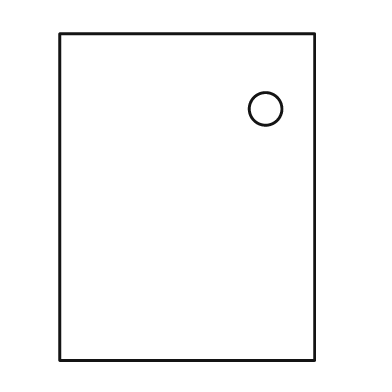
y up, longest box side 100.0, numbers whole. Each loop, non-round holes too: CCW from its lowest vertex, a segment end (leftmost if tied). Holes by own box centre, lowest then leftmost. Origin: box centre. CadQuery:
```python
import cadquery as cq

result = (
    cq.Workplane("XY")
    .moveTo(-39.0, -50.0)
    .lineTo(39.0, -50.0)
    .lineTo(39.0, 50.0)
    .lineTo(-39.0, 50.0)
    .close()
    .moveTo(24.0, 27.0)
    .circle(5.0)
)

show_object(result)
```